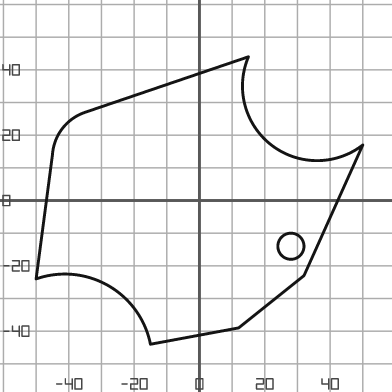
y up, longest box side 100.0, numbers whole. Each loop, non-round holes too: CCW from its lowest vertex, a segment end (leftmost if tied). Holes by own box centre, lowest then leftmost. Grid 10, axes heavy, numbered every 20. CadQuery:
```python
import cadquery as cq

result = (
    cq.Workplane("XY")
    .moveTo(-15.0, -44.0)
    .lineTo(12.0, -39.0)
    .lineTo(32.0, -23.0)
    .lineTo(50.0, 17.0)
    .threePointArc((22.0, 17.0), (15.0, 44.0))
    .lineTo(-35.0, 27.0)
    .threePointArc((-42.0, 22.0), (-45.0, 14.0))
    .lineTo(-50.0, -24.0)
    .threePointArc((-28.0, -26.0), (-15.0, -44.0))
    .close()
    .moveTo(28.0, -14.0)
    .circle(4.0)
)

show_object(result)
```